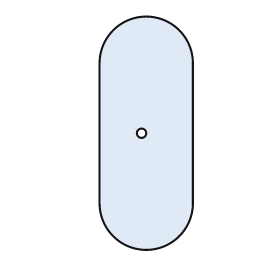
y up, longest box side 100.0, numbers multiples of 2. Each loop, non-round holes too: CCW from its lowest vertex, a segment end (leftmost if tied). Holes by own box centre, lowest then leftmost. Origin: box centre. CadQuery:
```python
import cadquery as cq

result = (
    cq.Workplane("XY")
    .moveTo(-20.0, -30.0)
    .threePointArc((0.0, -50.0), (20.0, -30.0))
    .lineTo(20.0, 30.0)
    .threePointArc((0.0, 50.0), (-20.0, 30.0))
    .close()
    .moveTo(-2.0, 0.0)
    .circle(2.0)
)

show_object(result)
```